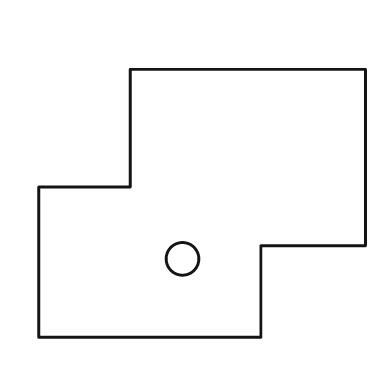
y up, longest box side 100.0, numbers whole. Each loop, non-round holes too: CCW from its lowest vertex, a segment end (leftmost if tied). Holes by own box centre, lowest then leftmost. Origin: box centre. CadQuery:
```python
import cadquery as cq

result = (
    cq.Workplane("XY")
    .moveTo(-50.0, -41.0)
    .lineTo(18.0, -41.0)
    .lineTo(18.0, -13.0)
    .lineTo(50.0, -13.0)
    .lineTo(50.0, 41.0)
    .lineTo(-22.0, 41.0)
    .lineTo(-22.0, 5.0)
    .lineTo(-50.0, 5.0)
    .close()
    .moveTo(-6.0, -17.0)
    .circle(5.0)
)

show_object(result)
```